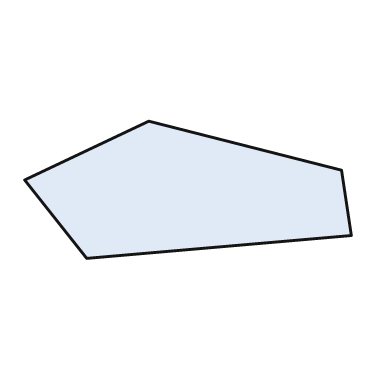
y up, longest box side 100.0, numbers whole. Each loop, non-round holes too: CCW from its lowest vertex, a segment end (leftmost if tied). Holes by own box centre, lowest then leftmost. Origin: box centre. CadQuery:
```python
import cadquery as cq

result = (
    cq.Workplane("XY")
    .moveTo(-31.0, -21.0)
    .lineTo(50.0, -14.0)
    .lineTo(47.0, 6.0)
    .lineTo(-12.0, 21.0)
    .lineTo(-50.0, 3.0)
    .close()
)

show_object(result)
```